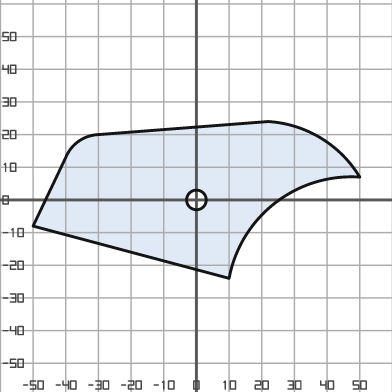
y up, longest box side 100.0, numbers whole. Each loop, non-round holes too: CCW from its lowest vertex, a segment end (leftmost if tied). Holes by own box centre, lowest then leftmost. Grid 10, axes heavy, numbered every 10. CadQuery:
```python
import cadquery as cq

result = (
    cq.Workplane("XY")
    .moveTo(10.0, -24.0)
    .threePointArc((24.0, -1.0), (50.0, 7.0))
    .threePointArc((38.0, 19.0), (22.0, 24.0))
    .lineTo(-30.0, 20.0)
    .threePointArc((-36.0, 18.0), (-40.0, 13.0))
    .lineTo(-50.0, -8.0)
    .close()
    .moveTo(0.0, 0.0)
    .circle(3.0)
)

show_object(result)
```